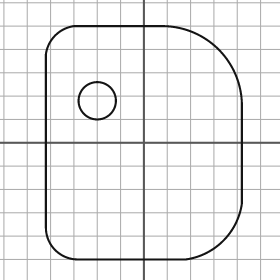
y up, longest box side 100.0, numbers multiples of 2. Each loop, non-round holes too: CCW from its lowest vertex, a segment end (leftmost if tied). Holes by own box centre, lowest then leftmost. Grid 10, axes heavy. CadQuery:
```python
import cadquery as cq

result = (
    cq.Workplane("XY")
    .moveTo(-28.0, -50.0)
    .lineTo(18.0, -50.0)
    .threePointArc((34.0, -42.0), (42.0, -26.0))
    .lineTo(42.0, 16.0)
    .threePointArc((32.0, 40.0), (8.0, 50.0))
    .lineTo(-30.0, 50.0)
    .threePointArc((-38.0, 46.0), (-42.0, 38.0))
    .lineTo(-42.0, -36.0)
    .threePointArc((-38.0, -46.0), (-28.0, -50.0))
    .close()
    .moveTo(-20.0, 18.0)
    .circle(8.0)
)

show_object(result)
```